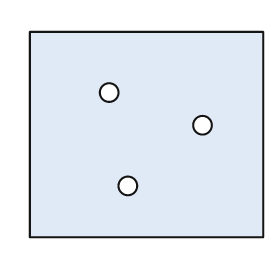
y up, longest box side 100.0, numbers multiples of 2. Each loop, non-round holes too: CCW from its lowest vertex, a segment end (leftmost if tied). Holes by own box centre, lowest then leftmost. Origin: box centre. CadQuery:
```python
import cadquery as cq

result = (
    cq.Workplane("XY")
    .moveTo(-50.0, -44.0)
    .lineTo(50.0, -44.0)
    .lineTo(50.0, 44.0)
    .lineTo(-50.0, 44.0)
    .close()
    .moveTo(-8.0, -22.0)
    .circle(4.0)
    .moveTo(24.0, 4.0)
    .circle(4.0)
    .moveTo(-16.0, 18.0)
    .circle(4.0)
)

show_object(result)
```